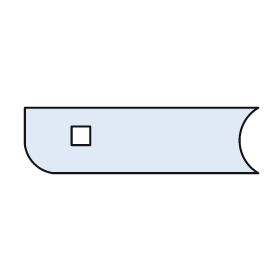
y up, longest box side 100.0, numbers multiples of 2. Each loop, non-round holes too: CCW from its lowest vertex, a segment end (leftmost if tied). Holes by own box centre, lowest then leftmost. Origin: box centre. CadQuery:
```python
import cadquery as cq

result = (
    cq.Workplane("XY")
    .moveTo(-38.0, -14.0)
    .lineTo(50.0, -14.0)
    .threePointArc((42.0, 0.0), (50.0, 14.0))
    .lineTo(-50.0, 14.0)
    .lineTo(-50.0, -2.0)
    .threePointArc((-46.0, -10.0), (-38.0, -14.0))
    .close()
    .moveTo(-30.0, -2.0)
    .lineTo(-22.0, -2.0)
    .lineTo(-22.0, 6.0)
    .lineTo(-30.0, 6.0)
    .close()
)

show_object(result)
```